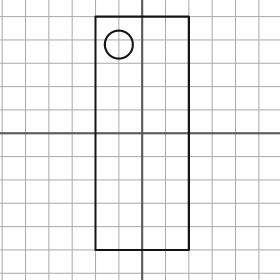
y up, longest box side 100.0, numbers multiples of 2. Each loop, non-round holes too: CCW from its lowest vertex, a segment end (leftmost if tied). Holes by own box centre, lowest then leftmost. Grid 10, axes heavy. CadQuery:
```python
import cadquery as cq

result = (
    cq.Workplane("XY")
    .moveTo(-20.0, -50.0)
    .lineTo(20.0, -50.0)
    .lineTo(20.0, 50.0)
    .lineTo(-20.0, 50.0)
    .close()
    .moveTo(-10.0, 38.0)
    .circle(6.0)
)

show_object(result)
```